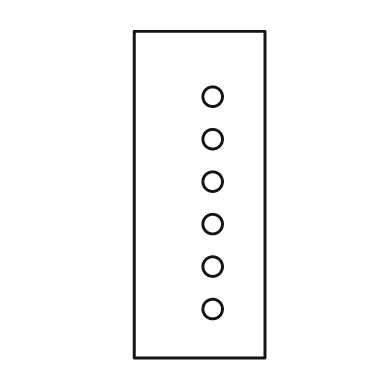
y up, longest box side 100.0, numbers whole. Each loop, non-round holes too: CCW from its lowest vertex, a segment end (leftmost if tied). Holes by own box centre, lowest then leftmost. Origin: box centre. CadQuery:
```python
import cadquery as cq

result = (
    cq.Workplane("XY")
    .moveTo(-20.0, -50.0)
    .lineTo(20.0, -50.0)
    .lineTo(20.0, 50.0)
    .lineTo(-20.0, 50.0)
    .close()
    .moveTo(4.0, -35.0)
    .circle(3.0)
    .moveTo(4.0, -22.0)
    .circle(3.0)
    .moveTo(4.0, -9.0)
    .circle(3.0)
    .moveTo(4.0, 4.0)
    .circle(3.0)
    .moveTo(4.0, 17.0)
    .circle(3.0)
    .moveTo(4.0, 30.0)
    .circle(3.0)
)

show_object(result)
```